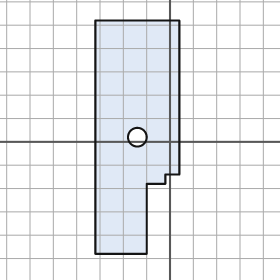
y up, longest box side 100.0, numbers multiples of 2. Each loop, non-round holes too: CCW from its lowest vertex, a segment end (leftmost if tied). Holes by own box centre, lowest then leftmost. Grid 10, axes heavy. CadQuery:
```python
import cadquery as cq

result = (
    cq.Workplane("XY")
    .moveTo(-32.0, -48.0)
    .lineTo(-10.0, -48.0)
    .lineTo(-10.0, -18.0)
    .lineTo(-2.0, -18.0)
    .lineTo(-2.0, -14.0)
    .lineTo(4.0, -14.0)
    .lineTo(4.0, 52.0)
    .lineTo(-32.0, 52.0)
    .close()
    .moveTo(-14.0, 2.0)
    .circle(4.0)
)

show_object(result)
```